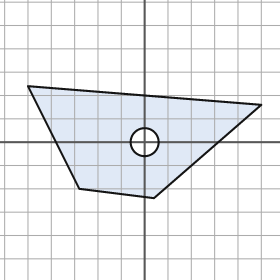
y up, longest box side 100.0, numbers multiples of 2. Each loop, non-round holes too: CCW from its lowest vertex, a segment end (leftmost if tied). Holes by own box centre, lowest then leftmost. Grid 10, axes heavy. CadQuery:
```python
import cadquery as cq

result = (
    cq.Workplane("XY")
    .moveTo(4.0, -24.0)
    .lineTo(50.0, 16.0)
    .lineTo(-50.0, 24.0)
    .lineTo(-28.0, -20.0)
    .close()
    .moveTo(0.0, 0.0)
    .circle(6.0)
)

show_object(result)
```